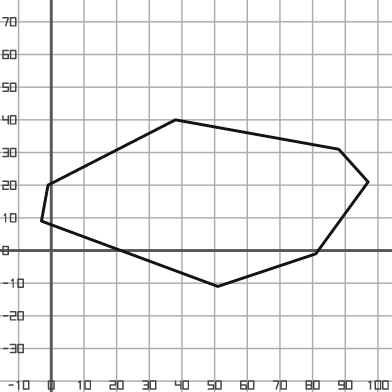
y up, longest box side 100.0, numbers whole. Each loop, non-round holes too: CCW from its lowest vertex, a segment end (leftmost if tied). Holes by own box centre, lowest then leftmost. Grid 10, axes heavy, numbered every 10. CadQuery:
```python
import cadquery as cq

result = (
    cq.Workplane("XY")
    .moveTo(51.0, -11.0)
    .lineTo(81.0, -1.0)
    .lineTo(97.0, 21.0)
    .lineTo(88.0, 31.0)
    .lineTo(38.0, 40.0)
    .lineTo(-1.0, 20.0)
    .lineTo(-3.0, 9.0)
    .close()
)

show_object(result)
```